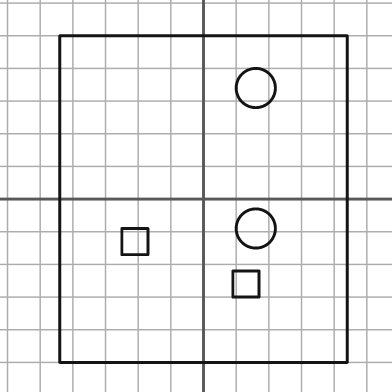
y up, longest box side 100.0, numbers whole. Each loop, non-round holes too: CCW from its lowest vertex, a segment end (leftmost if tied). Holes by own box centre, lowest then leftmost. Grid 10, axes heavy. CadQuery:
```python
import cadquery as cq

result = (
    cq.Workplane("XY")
    .moveTo(-44.0, -50.0)
    .lineTo(44.0, -50.0)
    .lineTo(44.0, 50.0)
    .lineTo(-44.0, 50.0)
    .close()
    .moveTo(9.0, -30.0)
    .lineTo(17.0, -30.0)
    .lineTo(17.0, -22.0)
    .lineTo(9.0, -22.0)
    .close()
    .moveTo(-25.0, -17.0)
    .lineTo(-17.0, -17.0)
    .lineTo(-17.0, -9.0)
    .lineTo(-25.0, -9.0)
    .close()
    .moveTo(16.0, -9.0)
    .circle(6.0)
    .moveTo(16.0, 34.0)
    .circle(6.0)
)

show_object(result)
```